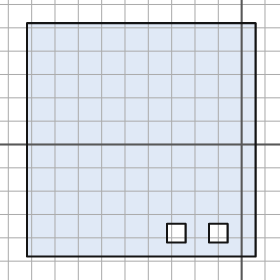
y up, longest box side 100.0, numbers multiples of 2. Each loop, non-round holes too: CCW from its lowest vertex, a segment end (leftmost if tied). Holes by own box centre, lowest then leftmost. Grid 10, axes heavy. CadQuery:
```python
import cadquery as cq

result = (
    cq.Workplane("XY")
    .moveTo(-92.0, -48.0)
    .lineTo(6.0, -48.0)
    .lineTo(6.0, 52.0)
    .lineTo(-92.0, 52.0)
    .close()
    .moveTo(-32.0, -42.0)
    .lineTo(-24.0, -42.0)
    .lineTo(-24.0, -34.0)
    .lineTo(-32.0, -34.0)
    .close()
    .moveTo(-14.0, -42.0)
    .lineTo(-6.0, -42.0)
    .lineTo(-6.0, -34.0)
    .lineTo(-14.0, -34.0)
    .close()
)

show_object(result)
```